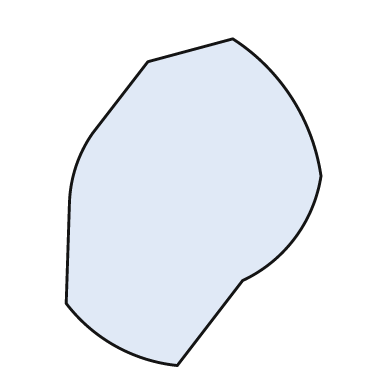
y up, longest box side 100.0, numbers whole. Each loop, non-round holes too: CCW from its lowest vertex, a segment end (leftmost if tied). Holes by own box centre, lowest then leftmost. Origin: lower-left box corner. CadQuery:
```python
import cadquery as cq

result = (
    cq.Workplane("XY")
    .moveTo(34.0, 0.0)
    .lineTo(54.0, 26.0)
    .threePointArc((70.0, 39.0), (78.0, 58.0))
    .threePointArc((69.0, 82.0), (51.0, 100.0))
    .lineTo(25.0, 93.0)
    .lineTo(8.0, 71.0)
    .threePointArc((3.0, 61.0), (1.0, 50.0))
    .lineTo(0.0, 19.0)
    .threePointArc((15.0, 6.0), (34.0, 0.0))
    .close()
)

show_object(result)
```